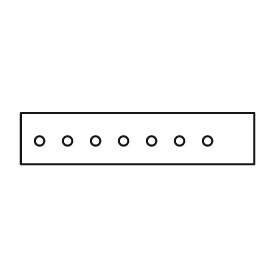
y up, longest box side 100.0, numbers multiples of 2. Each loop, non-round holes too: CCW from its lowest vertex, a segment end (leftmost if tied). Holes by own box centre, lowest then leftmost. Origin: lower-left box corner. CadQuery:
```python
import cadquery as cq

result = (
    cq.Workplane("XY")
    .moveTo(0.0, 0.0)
    .lineTo(100.0, 0.0)
    .lineTo(100.0, 22.0)
    .lineTo(0.0, 22.0)
    .close()
    .moveTo(8.0, 10.0)
    .circle(2.0)
    .moveTo(20.0, 10.0)
    .circle(2.0)
    .moveTo(32.0, 10.0)
    .circle(2.0)
    .moveTo(44.0, 10.0)
    .circle(2.0)
    .moveTo(56.0, 10.0)
    .circle(2.0)
    .moveTo(68.0, 10.0)
    .circle(2.0)
    .moveTo(80.0, 10.0)
    .circle(2.0)
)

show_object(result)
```